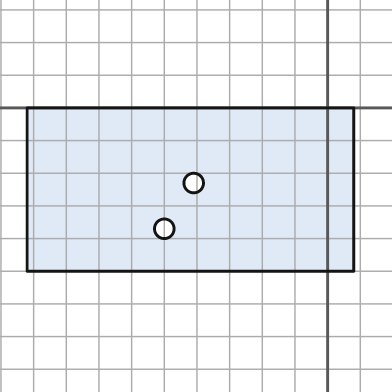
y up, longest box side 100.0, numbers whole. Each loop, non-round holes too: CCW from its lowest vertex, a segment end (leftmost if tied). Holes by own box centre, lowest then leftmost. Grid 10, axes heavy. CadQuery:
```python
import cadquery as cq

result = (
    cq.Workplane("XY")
    .moveTo(-92.0, -50.0)
    .lineTo(8.0, -50.0)
    .lineTo(8.0, 0.0)
    .lineTo(-92.0, 0.0)
    .close()
    .moveTo(-50.0, -37.0)
    .circle(3.0)
    .moveTo(-41.0, -23.0)
    .circle(3.0)
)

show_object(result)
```